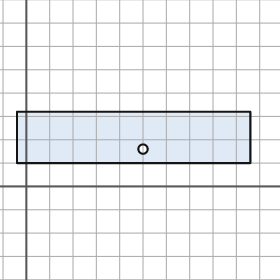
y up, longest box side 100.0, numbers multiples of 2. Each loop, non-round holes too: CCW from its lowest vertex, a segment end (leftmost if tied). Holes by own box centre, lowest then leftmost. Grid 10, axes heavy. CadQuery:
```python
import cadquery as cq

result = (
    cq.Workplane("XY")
    .moveTo(-4.0, 10.0)
    .lineTo(96.0, 10.0)
    .lineTo(96.0, 32.0)
    .lineTo(-4.0, 32.0)
    .close()
    .moveTo(50.0, 16.0)
    .circle(2.0)
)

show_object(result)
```